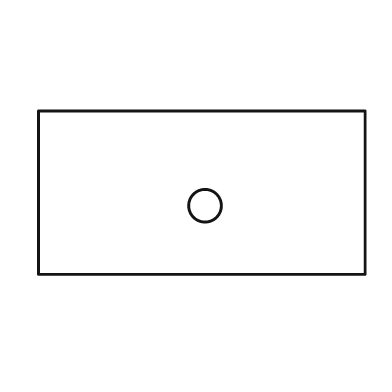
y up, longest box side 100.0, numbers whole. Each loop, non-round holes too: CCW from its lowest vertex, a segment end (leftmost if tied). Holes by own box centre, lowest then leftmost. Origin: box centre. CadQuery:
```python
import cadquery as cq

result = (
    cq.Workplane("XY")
    .moveTo(-50.0, -25.0)
    .lineTo(50.0, -25.0)
    .lineTo(50.0, 25.0)
    .lineTo(-50.0, 25.0)
    .close()
    .moveTo(1.0, -4.0)
    .circle(5.0)
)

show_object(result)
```